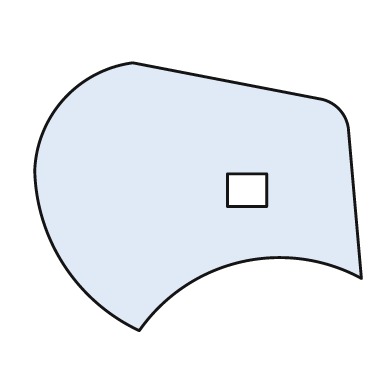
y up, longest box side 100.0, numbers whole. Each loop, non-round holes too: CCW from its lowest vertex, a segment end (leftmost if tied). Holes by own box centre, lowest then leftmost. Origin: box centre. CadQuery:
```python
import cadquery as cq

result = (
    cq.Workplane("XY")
    .moveTo(-18.0, -41.0)
    .threePointArc((13.0, -20.0), (50.0, -25.0))
    .lineTo(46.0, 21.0)
    .threePointArc((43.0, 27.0), (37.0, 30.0))
    .lineTo(-20.0, 41.0)
    .threePointArc((-41.0, 30.0), (-50.0, 8.0))
    .threePointArc((-41.0, -21.0), (-18.0, -41.0))
    .close()
    .moveTo(9.0, -3.0)
    .lineTo(21.0, -3.0)
    .lineTo(21.0, 7.0)
    .lineTo(9.0, 7.0)
    .close()
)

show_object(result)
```